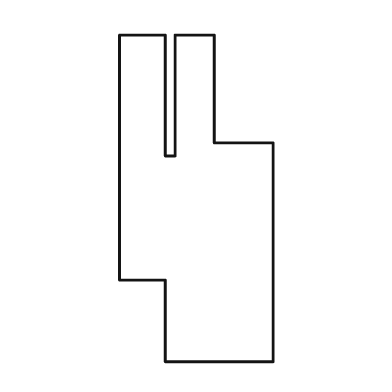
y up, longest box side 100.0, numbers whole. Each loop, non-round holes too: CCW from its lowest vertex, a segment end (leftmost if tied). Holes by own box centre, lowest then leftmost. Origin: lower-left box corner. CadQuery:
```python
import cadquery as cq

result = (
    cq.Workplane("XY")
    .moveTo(14.0, 0.0)
    .lineTo(47.0, 0.0)
    .lineTo(47.0, 67.0)
    .lineTo(29.0, 67.0)
    .lineTo(29.0, 100.0)
    .lineTo(17.0, 100.0)
    .lineTo(17.0, 63.0)
    .lineTo(14.0, 63.0)
    .lineTo(14.0, 100.0)
    .lineTo(0.0, 100.0)
    .lineTo(0.0, 25.0)
    .lineTo(14.0, 25.0)
    .close()
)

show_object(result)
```